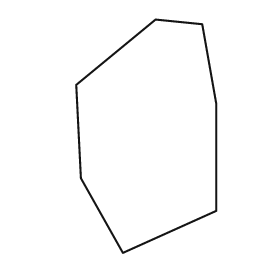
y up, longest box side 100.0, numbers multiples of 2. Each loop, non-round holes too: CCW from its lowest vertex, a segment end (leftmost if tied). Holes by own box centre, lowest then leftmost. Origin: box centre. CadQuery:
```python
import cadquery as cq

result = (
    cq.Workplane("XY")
    .moveTo(-10.0, -50.0)
    .lineTo(30.0, -32.0)
    .lineTo(30.0, 14.0)
    .lineTo(24.0, 48.0)
    .lineTo(4.0, 50.0)
    .lineTo(-30.0, 22.0)
    .lineTo(-28.0, -18.0)
    .close()
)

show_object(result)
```